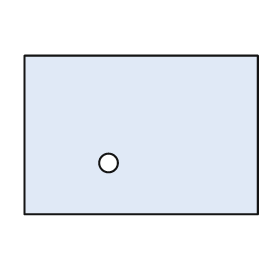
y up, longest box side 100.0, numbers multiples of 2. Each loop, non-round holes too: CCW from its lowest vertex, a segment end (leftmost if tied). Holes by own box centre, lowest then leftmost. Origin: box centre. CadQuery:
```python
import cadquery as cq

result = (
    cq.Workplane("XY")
    .moveTo(-50.0, -34.0)
    .lineTo(50.0, -34.0)
    .lineTo(50.0, 34.0)
    .lineTo(-50.0, 34.0)
    .close()
    .moveTo(-14.0, -12.0)
    .circle(4.0)
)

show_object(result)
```